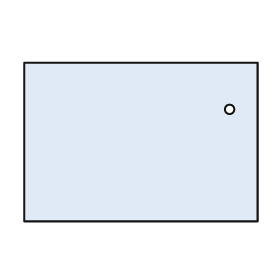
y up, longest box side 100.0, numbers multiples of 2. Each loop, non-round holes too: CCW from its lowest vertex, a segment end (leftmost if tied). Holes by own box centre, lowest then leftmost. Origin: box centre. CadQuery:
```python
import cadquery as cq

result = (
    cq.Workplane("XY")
    .moveTo(-50.0, -34.0)
    .lineTo(50.0, -34.0)
    .lineTo(50.0, 34.0)
    .lineTo(-50.0, 34.0)
    .close()
    .moveTo(38.0, 14.0)
    .circle(2.0)
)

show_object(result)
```